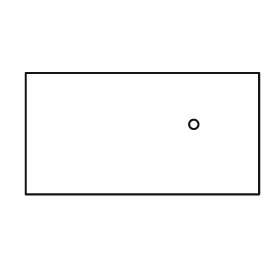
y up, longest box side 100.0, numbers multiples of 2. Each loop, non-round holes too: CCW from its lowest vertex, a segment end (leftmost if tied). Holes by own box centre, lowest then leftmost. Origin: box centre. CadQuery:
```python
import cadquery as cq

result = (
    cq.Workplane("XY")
    .moveTo(-50.0, -26.0)
    .lineTo(50.0, -26.0)
    .lineTo(50.0, 26.0)
    .lineTo(-50.0, 26.0)
    .close()
    .moveTo(22.0, 4.0)
    .circle(2.0)
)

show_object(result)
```